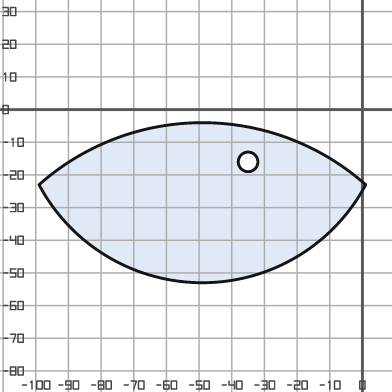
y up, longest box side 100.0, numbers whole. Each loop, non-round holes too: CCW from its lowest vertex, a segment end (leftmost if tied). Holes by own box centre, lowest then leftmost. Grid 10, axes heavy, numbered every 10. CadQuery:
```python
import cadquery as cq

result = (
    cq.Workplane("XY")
    .moveTo(-99.0, -23.0)
    .threePointArc((-49.0, -53.0), (1.0, -23.0))
    .threePointArc((-49.0, -4.0), (-99.0, -23.0))
    .close()
    .moveTo(-35.0, -16.0)
    .circle(3.0)
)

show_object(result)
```